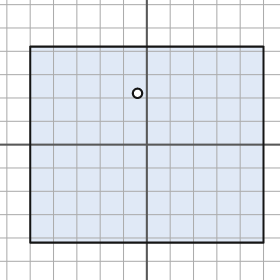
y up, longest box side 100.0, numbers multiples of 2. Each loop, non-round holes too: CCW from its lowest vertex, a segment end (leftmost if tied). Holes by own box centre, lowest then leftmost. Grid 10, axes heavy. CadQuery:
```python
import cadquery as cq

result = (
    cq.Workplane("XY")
    .moveTo(-50.0, -42.0)
    .lineTo(50.0, -42.0)
    .lineTo(50.0, 42.0)
    .lineTo(-50.0, 42.0)
    .close()
    .moveTo(-4.0, 22.0)
    .circle(2.0)
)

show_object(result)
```